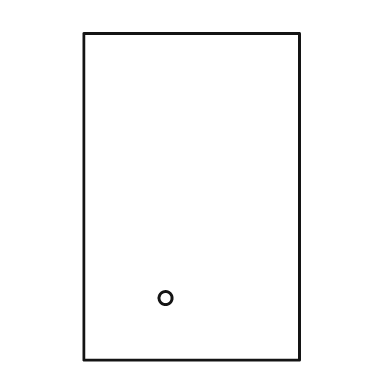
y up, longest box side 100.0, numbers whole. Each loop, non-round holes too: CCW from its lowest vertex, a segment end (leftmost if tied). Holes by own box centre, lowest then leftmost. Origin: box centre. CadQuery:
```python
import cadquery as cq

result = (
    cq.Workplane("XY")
    .moveTo(-33.0, -50.0)
    .lineTo(33.0, -50.0)
    .lineTo(33.0, 50.0)
    .lineTo(-33.0, 50.0)
    .close()
    .moveTo(-8.0, -31.0)
    .circle(2.0)
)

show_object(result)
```